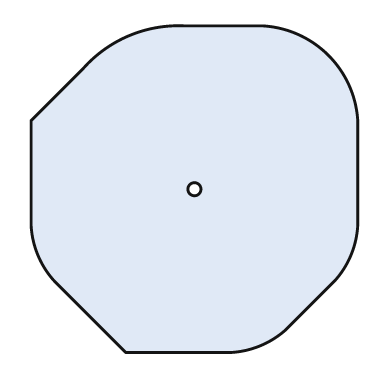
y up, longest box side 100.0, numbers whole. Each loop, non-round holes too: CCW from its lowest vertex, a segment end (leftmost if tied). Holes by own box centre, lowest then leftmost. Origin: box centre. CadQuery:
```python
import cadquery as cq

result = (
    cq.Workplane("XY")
    .moveTo(-21.0, -50.0)
    .lineTo(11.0, -50.0)
    .threePointArc((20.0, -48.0), (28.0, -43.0))
    .lineTo(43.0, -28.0)
    .threePointArc((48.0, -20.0), (50.0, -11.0))
    .lineTo(50.0, 21.0)
    .threePointArc((41.0, 41.0), (21.0, 50.0))
    .lineTo(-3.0, 50.0)
    .threePointArc((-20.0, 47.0), (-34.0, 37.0))
    .lineTo(-50.0, 21.0)
    .lineTo(-50.0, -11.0)
    .threePointArc((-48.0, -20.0), (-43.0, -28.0))
    .close()
    .moveTo(0.0, 0.0)
    .circle(2.0)
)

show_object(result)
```